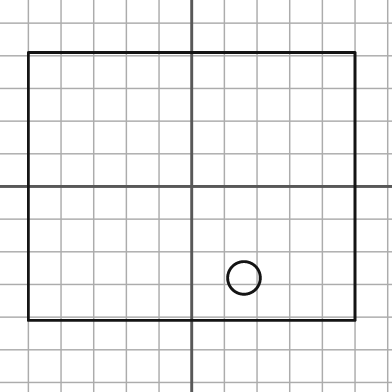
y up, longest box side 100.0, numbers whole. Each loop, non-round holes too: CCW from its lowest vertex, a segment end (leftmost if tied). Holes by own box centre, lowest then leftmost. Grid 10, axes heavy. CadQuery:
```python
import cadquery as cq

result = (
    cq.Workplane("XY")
    .moveTo(-50.0, -41.0)
    .lineTo(50.0, -41.0)
    .lineTo(50.0, 41.0)
    .lineTo(-50.0, 41.0)
    .close()
    .moveTo(16.0, -28.0)
    .circle(5.0)
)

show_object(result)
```